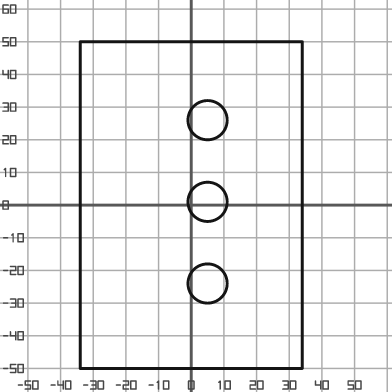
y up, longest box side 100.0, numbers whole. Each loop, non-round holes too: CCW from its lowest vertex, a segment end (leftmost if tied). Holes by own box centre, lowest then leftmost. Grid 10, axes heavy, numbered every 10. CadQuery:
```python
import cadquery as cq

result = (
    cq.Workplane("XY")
    .moveTo(-34.0, -50.0)
    .lineTo(34.0, -50.0)
    .lineTo(34.0, 50.0)
    .lineTo(-34.0, 50.0)
    .close()
    .moveTo(5.0, -24.0)
    .circle(6.0)
    .moveTo(5.0, 1.0)
    .circle(6.0)
    .moveTo(5.0, 26.0)
    .circle(6.0)
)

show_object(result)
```